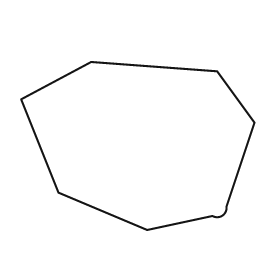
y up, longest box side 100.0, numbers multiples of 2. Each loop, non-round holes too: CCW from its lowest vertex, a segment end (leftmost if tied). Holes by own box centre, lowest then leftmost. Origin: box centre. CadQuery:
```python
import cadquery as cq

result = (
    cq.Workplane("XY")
    .moveTo(4.0, -36.0)
    .lineTo(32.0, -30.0)
    .threePointArc((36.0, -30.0), (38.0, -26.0))
    .lineTo(50.0, 10.0)
    .lineTo(34.0, 32.0)
    .lineTo(-20.0, 36.0)
    .lineTo(-50.0, 20.0)
    .lineTo(-34.0, -20.0)
    .close()
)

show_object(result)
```